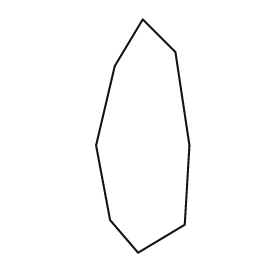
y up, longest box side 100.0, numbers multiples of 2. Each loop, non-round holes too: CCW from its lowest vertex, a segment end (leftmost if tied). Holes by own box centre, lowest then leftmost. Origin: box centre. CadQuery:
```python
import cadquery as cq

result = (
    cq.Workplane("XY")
    .moveTo(-2.0, -50.0)
    .lineTo(18.0, -38.0)
    .lineTo(20.0, -4.0)
    .lineTo(14.0, 36.0)
    .lineTo(0.0, 50.0)
    .lineTo(-12.0, 30.0)
    .lineTo(-20.0, -4.0)
    .lineTo(-14.0, -36.0)
    .close()
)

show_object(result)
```